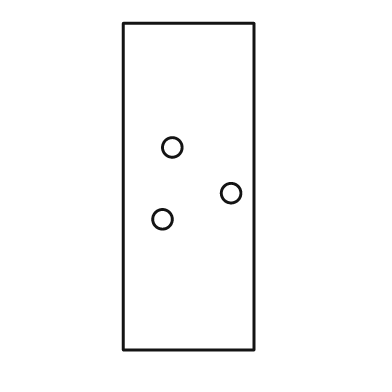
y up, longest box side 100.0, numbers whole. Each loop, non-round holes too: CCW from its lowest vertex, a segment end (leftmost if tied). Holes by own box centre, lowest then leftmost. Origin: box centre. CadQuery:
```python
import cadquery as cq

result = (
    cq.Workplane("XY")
    .moveTo(-20.0, -50.0)
    .lineTo(20.0, -50.0)
    .lineTo(20.0, 50.0)
    .lineTo(-20.0, 50.0)
    .close()
    .moveTo(-8.0, -10.0)
    .circle(3.0)
    .moveTo(13.0, -2.0)
    .circle(3.0)
    .moveTo(-5.0, 12.0)
    .circle(3.0)
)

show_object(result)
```